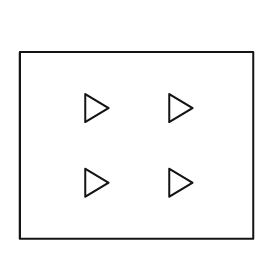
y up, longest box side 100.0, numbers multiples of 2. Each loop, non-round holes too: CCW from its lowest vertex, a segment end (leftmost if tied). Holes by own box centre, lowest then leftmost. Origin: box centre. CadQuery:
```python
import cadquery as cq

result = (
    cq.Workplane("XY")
    .moveTo(-50.0, -40.0)
    .lineTo(50.0, -40.0)
    .lineTo(50.0, 40.0)
    .lineTo(-50.0, 40.0)
    .close()
    .moveTo(-22.0, -22.0)
    .lineTo(-12.0, -16.0)
    .lineTo(-22.0, -10.0)
    .close()
    .moveTo(14.0, -22.0)
    .lineTo(24.0, -16.0)
    .lineTo(14.0, -10.0)
    .close()
    .moveTo(-22.0, 10.0)
    .lineTo(-12.0, 16.0)
    .lineTo(-22.0, 22.0)
    .close()
    .moveTo(14.0, 10.0)
    .lineTo(24.0, 16.0)
    .lineTo(14.0, 22.0)
    .close()
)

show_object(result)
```